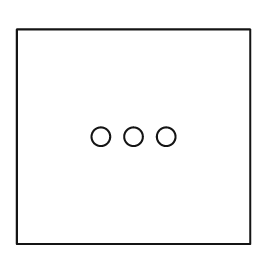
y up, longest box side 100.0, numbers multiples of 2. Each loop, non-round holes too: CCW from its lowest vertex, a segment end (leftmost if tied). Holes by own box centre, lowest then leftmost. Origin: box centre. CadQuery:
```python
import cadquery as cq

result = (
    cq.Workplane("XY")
    .moveTo(-50.0, -46.0)
    .lineTo(50.0, -46.0)
    .lineTo(50.0, 46.0)
    .lineTo(-50.0, 46.0)
    .close()
    .moveTo(-14.0, 0.0)
    .circle(4.0)
    .moveTo(0.0, 0.0)
    .circle(4.0)
    .moveTo(14.0, 0.0)
    .circle(4.0)
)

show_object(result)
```